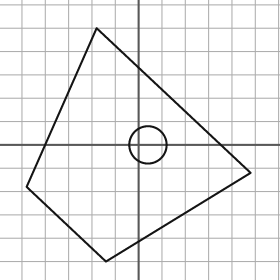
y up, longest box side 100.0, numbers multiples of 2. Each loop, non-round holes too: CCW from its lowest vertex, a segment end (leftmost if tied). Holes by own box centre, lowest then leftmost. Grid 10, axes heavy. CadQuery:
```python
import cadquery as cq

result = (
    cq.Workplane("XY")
    .moveTo(-14.0, -50.0)
    .lineTo(48.0, -12.0)
    .lineTo(-18.0, 50.0)
    .lineTo(-48.0, -18.0)
    .close()
    .moveTo(4.0, 0.0)
    .circle(8.0)
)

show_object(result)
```